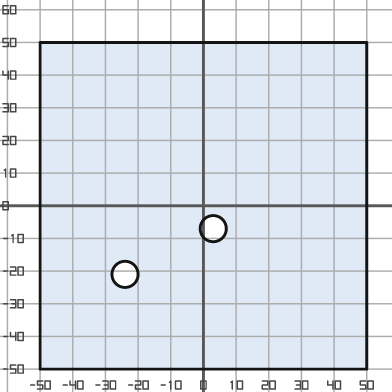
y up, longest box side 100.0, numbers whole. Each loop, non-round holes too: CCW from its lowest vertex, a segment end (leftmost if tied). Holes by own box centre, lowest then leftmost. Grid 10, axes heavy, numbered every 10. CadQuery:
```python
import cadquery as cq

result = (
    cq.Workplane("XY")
    .moveTo(-50.0, -50.0)
    .lineTo(50.0, -50.0)
    .lineTo(50.0, 50.0)
    .lineTo(-50.0, 50.0)
    .close()
    .moveTo(-24.0, -21.0)
    .circle(4.0)
    .moveTo(3.0, -7.0)
    .circle(4.0)
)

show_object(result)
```